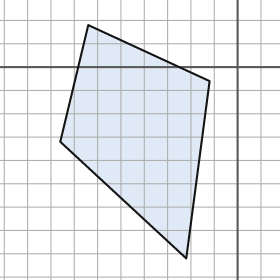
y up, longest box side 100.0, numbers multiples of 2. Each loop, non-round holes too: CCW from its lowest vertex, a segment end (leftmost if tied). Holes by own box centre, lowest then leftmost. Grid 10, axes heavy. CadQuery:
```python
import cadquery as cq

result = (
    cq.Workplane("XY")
    .moveTo(-22.0, -82.0)
    .lineTo(-12.0, -6.0)
    .lineTo(-64.0, 18.0)
    .lineTo(-76.0, -32.0)
    .close()
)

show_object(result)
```